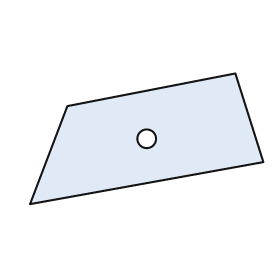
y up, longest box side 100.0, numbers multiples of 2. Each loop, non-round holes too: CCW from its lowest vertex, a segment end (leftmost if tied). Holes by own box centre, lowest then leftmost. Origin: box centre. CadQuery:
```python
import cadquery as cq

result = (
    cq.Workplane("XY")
    .moveTo(-50.0, -28.0)
    .lineTo(50.0, -10.0)
    .lineTo(38.0, 28.0)
    .lineTo(-34.0, 14.0)
    .close()
    .moveTo(0.0, 0.0)
    .circle(4.0)
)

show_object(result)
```